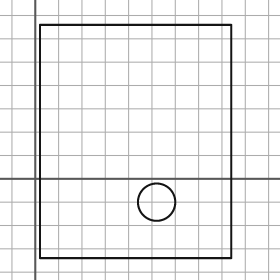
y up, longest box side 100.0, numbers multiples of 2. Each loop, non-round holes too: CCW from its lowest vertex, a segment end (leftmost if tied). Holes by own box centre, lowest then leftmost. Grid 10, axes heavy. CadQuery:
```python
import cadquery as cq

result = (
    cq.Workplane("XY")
    .moveTo(2.0, -34.0)
    .lineTo(84.0, -34.0)
    .lineTo(84.0, 66.0)
    .lineTo(2.0, 66.0)
    .close()
    .moveTo(52.0, -10.0)
    .circle(8.0)
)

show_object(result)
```